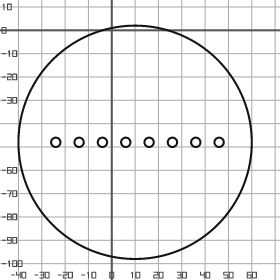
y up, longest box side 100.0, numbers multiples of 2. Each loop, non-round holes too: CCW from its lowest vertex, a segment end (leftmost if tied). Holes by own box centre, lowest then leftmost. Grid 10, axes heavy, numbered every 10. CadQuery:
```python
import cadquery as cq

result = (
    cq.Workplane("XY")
    .moveTo(10.0, -48.0)
    .circle(50.0)
    .moveTo(-24.0, -48.0)
    .circle(2.0)
    .moveTo(-14.0, -48.0)
    .circle(2.0)
    .moveTo(-4.0, -48.0)
    .circle(2.0)
    .moveTo(6.0, -48.0)
    .circle(2.0)
    .moveTo(16.0, -48.0)
    .circle(2.0)
    .moveTo(26.0, -48.0)
    .circle(2.0)
    .moveTo(36.0, -48.0)
    .circle(2.0)
    .moveTo(46.0, -48.0)
    .circle(2.0)
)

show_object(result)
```